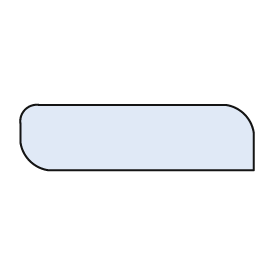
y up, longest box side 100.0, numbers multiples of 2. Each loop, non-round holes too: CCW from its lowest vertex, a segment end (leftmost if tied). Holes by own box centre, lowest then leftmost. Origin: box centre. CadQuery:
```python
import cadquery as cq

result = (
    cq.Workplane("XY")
    .moveTo(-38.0, -14.0)
    .lineTo(50.0, -14.0)
    .lineTo(50.0, 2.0)
    .threePointArc((46.0, 10.0), (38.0, 14.0))
    .lineTo(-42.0, 14.0)
    .threePointArc((-48.0, 12.0), (-50.0, 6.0))
    .lineTo(-50.0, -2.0)
    .threePointArc((-46.0, -10.0), (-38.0, -14.0))
    .close()
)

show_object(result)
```